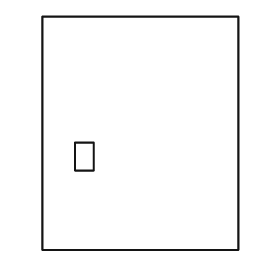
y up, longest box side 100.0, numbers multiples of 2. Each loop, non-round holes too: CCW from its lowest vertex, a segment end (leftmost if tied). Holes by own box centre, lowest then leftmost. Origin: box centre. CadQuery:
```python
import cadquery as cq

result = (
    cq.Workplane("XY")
    .moveTo(-42.0, -50.0)
    .lineTo(42.0, -50.0)
    .lineTo(42.0, 50.0)
    .lineTo(-42.0, 50.0)
    .close()
    .moveTo(-28.0, -16.0)
    .lineTo(-20.0, -16.0)
    .lineTo(-20.0, -4.0)
    .lineTo(-28.0, -4.0)
    .close()
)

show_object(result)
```